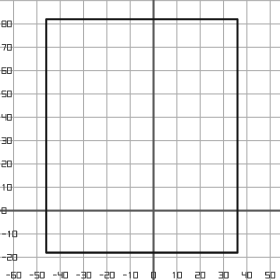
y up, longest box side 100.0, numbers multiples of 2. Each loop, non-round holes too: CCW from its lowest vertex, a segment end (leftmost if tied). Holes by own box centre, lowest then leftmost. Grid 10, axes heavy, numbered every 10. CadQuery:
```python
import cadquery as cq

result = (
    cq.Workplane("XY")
    .moveTo(-46.0, -18.0)
    .lineTo(36.0, -18.0)
    .lineTo(36.0, 82.0)
    .lineTo(-46.0, 82.0)
    .close()
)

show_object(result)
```